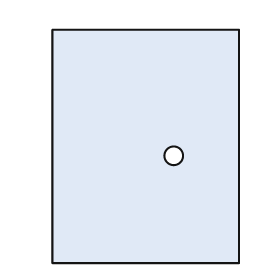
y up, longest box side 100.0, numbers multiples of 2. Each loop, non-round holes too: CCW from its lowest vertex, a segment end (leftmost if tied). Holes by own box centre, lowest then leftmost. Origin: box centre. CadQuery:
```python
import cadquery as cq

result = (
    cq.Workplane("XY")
    .moveTo(-40.0, -50.0)
    .lineTo(40.0, -50.0)
    .lineTo(40.0, 50.0)
    .lineTo(-40.0, 50.0)
    .close()
    .moveTo(12.0, -4.0)
    .circle(4.0)
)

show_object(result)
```